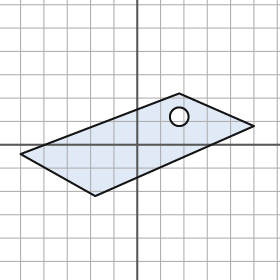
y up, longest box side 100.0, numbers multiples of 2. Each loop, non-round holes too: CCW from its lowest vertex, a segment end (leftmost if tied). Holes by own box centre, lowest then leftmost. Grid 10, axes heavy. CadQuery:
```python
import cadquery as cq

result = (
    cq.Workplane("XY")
    .moveTo(-18.0, -22.0)
    .lineTo(50.0, 8.0)
    .lineTo(18.0, 22.0)
    .lineTo(-50.0, -4.0)
    .close()
    .moveTo(18.0, 12.0)
    .circle(4.0)
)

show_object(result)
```